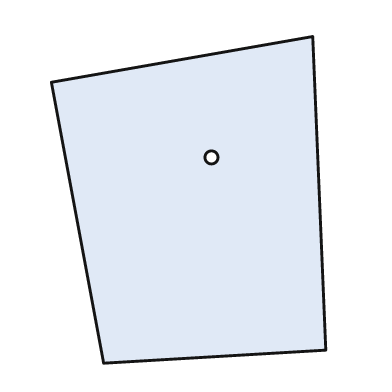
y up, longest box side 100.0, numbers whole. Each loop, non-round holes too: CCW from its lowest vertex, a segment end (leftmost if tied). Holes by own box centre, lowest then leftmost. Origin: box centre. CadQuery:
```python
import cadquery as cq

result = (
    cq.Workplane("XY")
    .moveTo(-26.0, -50.0)
    .lineTo(42.0, -46.0)
    .lineTo(38.0, 50.0)
    .lineTo(-42.0, 36.0)
    .close()
    .moveTo(7.0, 13.0)
    .circle(2.0)
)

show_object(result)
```